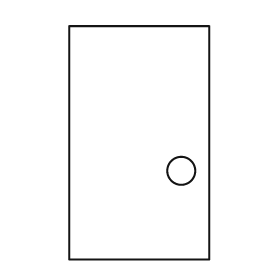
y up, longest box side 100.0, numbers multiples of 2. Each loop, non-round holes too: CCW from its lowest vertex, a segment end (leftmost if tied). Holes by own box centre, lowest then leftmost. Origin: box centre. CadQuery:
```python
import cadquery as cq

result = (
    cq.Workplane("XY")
    .moveTo(-30.0, -50.0)
    .lineTo(30.0, -50.0)
    .lineTo(30.0, 50.0)
    .lineTo(-30.0, 50.0)
    .close()
    .moveTo(18.0, -12.0)
    .circle(6.0)
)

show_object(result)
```